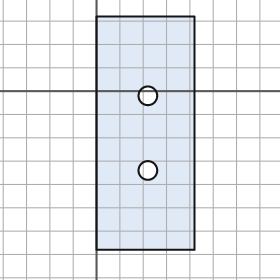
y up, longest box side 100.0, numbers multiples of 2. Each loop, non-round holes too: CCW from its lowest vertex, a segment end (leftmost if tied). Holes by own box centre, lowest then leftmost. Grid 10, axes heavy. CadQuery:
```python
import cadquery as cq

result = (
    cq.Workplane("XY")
    .moveTo(0.0, -68.0)
    .lineTo(42.0, -68.0)
    .lineTo(42.0, 32.0)
    .lineTo(0.0, 32.0)
    .close()
    .moveTo(22.0, -34.0)
    .circle(4.0)
    .moveTo(22.0, -2.0)
    .circle(4.0)
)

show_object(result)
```